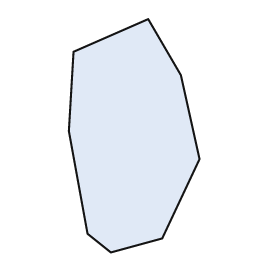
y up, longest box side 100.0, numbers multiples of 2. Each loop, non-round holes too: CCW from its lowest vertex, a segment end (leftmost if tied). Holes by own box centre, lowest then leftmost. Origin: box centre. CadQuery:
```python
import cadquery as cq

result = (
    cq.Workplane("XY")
    .moveTo(-10.0, -50.0)
    .lineTo(12.0, -44.0)
    .lineTo(28.0, -10.0)
    .lineTo(20.0, 26.0)
    .lineTo(6.0, 50.0)
    .lineTo(-26.0, 36.0)
    .lineTo(-28.0, 2.0)
    .lineTo(-20.0, -42.0)
    .close()
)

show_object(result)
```